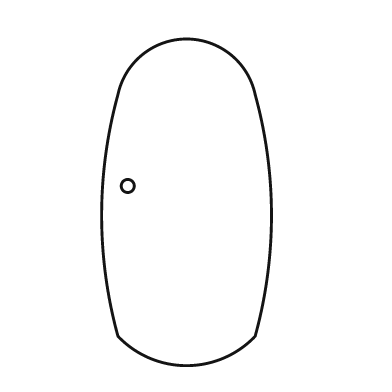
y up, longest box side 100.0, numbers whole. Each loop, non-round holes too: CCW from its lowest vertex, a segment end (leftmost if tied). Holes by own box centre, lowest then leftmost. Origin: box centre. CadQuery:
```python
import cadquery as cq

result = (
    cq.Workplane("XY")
    .moveTo(-21.0, -41.0)
    .threePointArc((0.0, -50.0), (21.0, -41.0))
    .threePointArc((26.0, -4.0), (21.0, 33.0))
    .threePointArc((0.0, 50.0), (-21.0, 33.0))
    .threePointArc((-26.0, -4.0), (-21.0, -41.0))
    .close()
    .moveTo(-18.0, 5.0)
    .circle(2.0)
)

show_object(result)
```